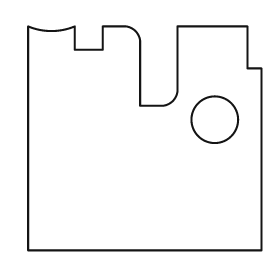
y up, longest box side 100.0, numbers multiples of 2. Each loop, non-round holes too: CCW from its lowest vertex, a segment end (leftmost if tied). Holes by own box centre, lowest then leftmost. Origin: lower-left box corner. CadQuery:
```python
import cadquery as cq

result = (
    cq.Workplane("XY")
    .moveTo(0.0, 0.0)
    .lineTo(100.0, 0.0)
    .lineTo(100.0, 78.0)
    .lineTo(94.0, 78.0)
    .lineTo(94.0, 96.0)
    .lineTo(64.0, 96.0)
    .lineTo(64.0, 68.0)
    .threePointArc((62.0, 64.0), (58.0, 62.0))
    .lineTo(48.0, 62.0)
    .lineTo(48.0, 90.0)
    .threePointArc((46.0, 94.0), (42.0, 96.0))
    .lineTo(32.0, 96.0)
    .lineTo(32.0, 86.0)
    .lineTo(20.0, 86.0)
    .lineTo(20.0, 96.0)
    .threePointArc((10.0, 94.0), (0.0, 96.0))
    .close()
    .moveTo(80.0, 56.0)
    .circle(10.0)
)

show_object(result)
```